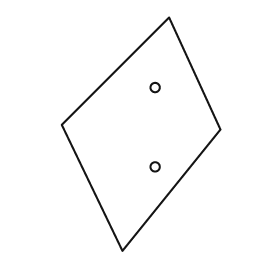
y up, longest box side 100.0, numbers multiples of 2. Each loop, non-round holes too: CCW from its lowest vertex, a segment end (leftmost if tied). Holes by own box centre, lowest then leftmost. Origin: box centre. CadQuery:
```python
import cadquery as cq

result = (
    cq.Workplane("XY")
    .moveTo(-8.0, -50.0)
    .lineTo(34.0, 2.0)
    .lineTo(12.0, 50.0)
    .lineTo(-34.0, 4.0)
    .close()
    .moveTo(6.0, -14.0)
    .circle(2.0)
    .moveTo(6.0, 20.0)
    .circle(2.0)
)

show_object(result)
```